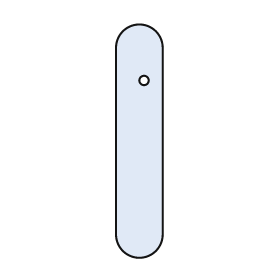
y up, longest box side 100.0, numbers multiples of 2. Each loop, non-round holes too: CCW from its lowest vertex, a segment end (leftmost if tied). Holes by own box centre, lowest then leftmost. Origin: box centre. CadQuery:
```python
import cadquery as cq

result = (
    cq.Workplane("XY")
    .moveTo(-10.0, -40.0)
    .threePointArc((0.0, -50.0), (10.0, -40.0))
    .lineTo(10.0, 40.0)
    .threePointArc((0.0, 50.0), (-10.0, 40.0))
    .close()
    .moveTo(2.0, 26.0)
    .circle(2.0)
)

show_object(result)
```